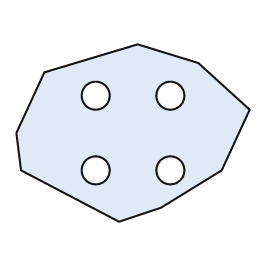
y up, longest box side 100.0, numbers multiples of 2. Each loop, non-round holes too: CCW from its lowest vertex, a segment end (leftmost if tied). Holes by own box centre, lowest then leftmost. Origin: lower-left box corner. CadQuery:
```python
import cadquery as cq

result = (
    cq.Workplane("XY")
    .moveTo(44.0, 0.0)
    .lineTo(62.0, 6.0)
    .lineTo(88.0, 22.0)
    .lineTo(100.0, 48.0)
    .lineTo(78.0, 68.0)
    .lineTo(52.0, 76.0)
    .lineTo(12.0, 64.0)
    .lineTo(0.0, 38.0)
    .lineTo(2.0, 22.0)
    .close()
    .moveTo(34.0, 22.0)
    .circle(6.0)
    .moveTo(66.0, 22.0)
    .circle(6.0)
    .moveTo(34.0, 54.0)
    .circle(6.0)
    .moveTo(66.0, 54.0)
    .circle(6.0)
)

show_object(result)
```